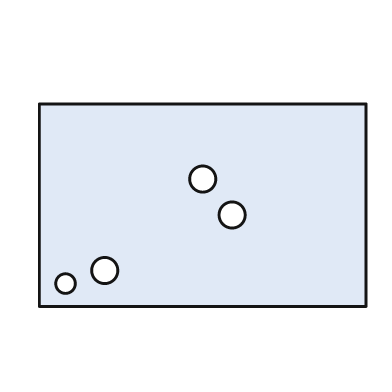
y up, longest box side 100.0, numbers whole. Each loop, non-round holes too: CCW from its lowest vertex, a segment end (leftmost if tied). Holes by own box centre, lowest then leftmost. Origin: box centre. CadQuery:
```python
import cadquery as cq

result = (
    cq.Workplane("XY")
    .moveTo(-50.0, -31.0)
    .lineTo(50.0, -31.0)
    .lineTo(50.0, 31.0)
    .lineTo(-50.0, 31.0)
    .close()
    .moveTo(-42.0, -24.0)
    .circle(3.0)
    .moveTo(-30.0, -20.0)
    .circle(4.0)
    .moveTo(9.0, -3.0)
    .circle(4.0)
    .moveTo(0.0, 8.0)
    .circle(4.0)
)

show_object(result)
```